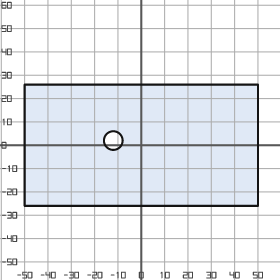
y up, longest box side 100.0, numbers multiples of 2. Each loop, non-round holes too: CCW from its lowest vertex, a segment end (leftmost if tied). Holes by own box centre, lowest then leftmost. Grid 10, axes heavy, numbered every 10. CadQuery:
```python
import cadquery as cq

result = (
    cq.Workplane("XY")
    .moveTo(-50.0, -26.0)
    .lineTo(50.0, -26.0)
    .lineTo(50.0, 26.0)
    .lineTo(-50.0, 26.0)
    .close()
    .moveTo(-12.0, 2.0)
    .circle(4.0)
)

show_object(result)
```